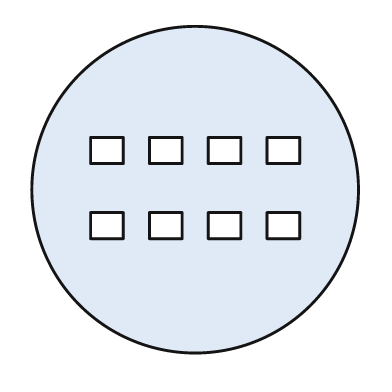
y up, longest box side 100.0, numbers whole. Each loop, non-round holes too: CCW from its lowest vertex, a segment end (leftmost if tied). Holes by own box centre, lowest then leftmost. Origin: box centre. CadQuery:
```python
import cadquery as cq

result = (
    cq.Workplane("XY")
    .moveTo(0.0, 0.0)
    .circle(50.0)
    .moveTo(-32.0, -15.0)
    .lineTo(-22.0, -15.0)
    .lineTo(-22.0, -7.0)
    .lineTo(-32.0, -7.0)
    .close()
    .moveTo(-14.0, -15.0)
    .lineTo(-4.0, -15.0)
    .lineTo(-4.0, -7.0)
    .lineTo(-14.0, -7.0)
    .close()
    .moveTo(4.0, -15.0)
    .lineTo(14.0, -15.0)
    .lineTo(14.0, -7.0)
    .lineTo(4.0, -7.0)
    .close()
    .moveTo(22.0, -15.0)
    .lineTo(32.0, -15.0)
    .lineTo(32.0, -7.0)
    .lineTo(22.0, -7.0)
    .close()
    .moveTo(-32.0, 8.0)
    .lineTo(-22.0, 8.0)
    .lineTo(-22.0, 16.0)
    .lineTo(-32.0, 16.0)
    .close()
    .moveTo(-14.0, 8.0)
    .lineTo(-4.0, 8.0)
    .lineTo(-4.0, 16.0)
    .lineTo(-14.0, 16.0)
    .close()
    .moveTo(4.0, 8.0)
    .lineTo(14.0, 8.0)
    .lineTo(14.0, 16.0)
    .lineTo(4.0, 16.0)
    .close()
    .moveTo(22.0, 8.0)
    .lineTo(32.0, 8.0)
    .lineTo(32.0, 16.0)
    .lineTo(22.0, 16.0)
    .close()
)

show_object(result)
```